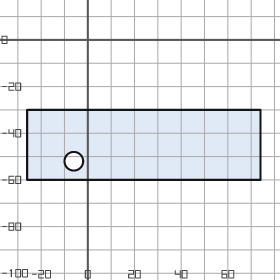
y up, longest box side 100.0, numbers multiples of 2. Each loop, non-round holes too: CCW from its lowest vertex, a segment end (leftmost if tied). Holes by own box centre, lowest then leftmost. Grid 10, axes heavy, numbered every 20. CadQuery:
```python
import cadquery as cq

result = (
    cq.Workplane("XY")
    .moveTo(-26.0, -60.0)
    .lineTo(74.0, -60.0)
    .lineTo(74.0, -30.0)
    .lineTo(-26.0, -30.0)
    .close()
    .moveTo(-6.0, -52.0)
    .circle(4.0)
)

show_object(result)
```